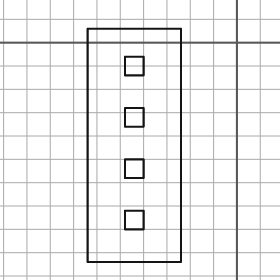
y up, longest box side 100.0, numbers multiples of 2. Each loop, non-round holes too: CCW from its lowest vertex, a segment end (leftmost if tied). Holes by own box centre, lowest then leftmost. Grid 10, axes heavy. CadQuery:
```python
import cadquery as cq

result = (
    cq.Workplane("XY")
    .moveTo(-64.0, -94.0)
    .lineTo(-24.0, -94.0)
    .lineTo(-24.0, 6.0)
    .lineTo(-64.0, 6.0)
    .close()
    .moveTo(-48.0, -80.0)
    .lineTo(-40.0, -80.0)
    .lineTo(-40.0, -72.0)
    .lineTo(-48.0, -72.0)
    .close()
    .moveTo(-48.0, -58.0)
    .lineTo(-40.0, -58.0)
    .lineTo(-40.0, -50.0)
    .lineTo(-48.0, -50.0)
    .close()
    .moveTo(-48.0, -36.0)
    .lineTo(-40.0, -36.0)
    .lineTo(-40.0, -28.0)
    .lineTo(-48.0, -28.0)
    .close()
    .moveTo(-48.0, -14.0)
    .lineTo(-40.0, -14.0)
    .lineTo(-40.0, -6.0)
    .lineTo(-48.0, -6.0)
    .close()
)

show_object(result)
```